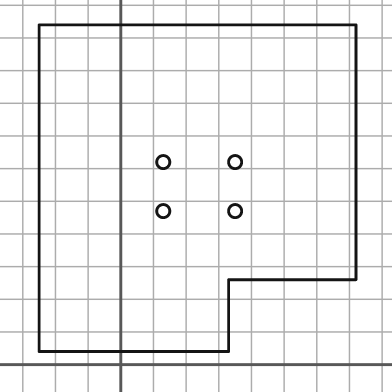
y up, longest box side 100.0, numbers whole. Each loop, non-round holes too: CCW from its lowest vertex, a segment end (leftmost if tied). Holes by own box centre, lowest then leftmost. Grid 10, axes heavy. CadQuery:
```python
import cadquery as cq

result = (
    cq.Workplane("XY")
    .moveTo(-25.0, 4.0)
    .lineTo(33.0, 4.0)
    .lineTo(33.0, 26.0)
    .lineTo(72.0, 26.0)
    .lineTo(72.0, 104.0)
    .lineTo(-25.0, 104.0)
    .close()
    .moveTo(13.0, 47.0)
    .circle(2.0)
    .moveTo(35.0, 47.0)
    .circle(2.0)
    .moveTo(13.0, 62.0)
    .circle(2.0)
    .moveTo(35.0, 62.0)
    .circle(2.0)
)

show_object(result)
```